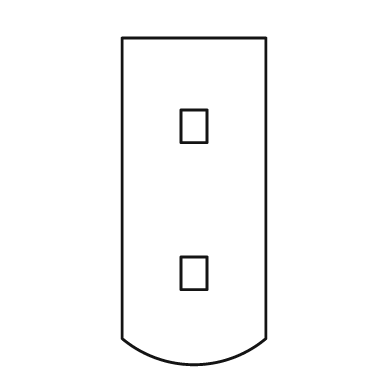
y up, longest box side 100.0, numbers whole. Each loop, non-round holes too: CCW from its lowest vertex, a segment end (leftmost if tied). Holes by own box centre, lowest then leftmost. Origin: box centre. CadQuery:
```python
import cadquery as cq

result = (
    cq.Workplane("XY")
    .moveTo(-22.0, -42.0)
    .threePointArc((0.0, -50.0), (22.0, -42.0))
    .lineTo(22.0, 50.0)
    .lineTo(-22.0, 50.0)
    .close()
    .moveTo(-4.0, -27.0)
    .lineTo(4.0, -27.0)
    .lineTo(4.0, -17.0)
    .lineTo(-4.0, -17.0)
    .close()
    .moveTo(-4.0, 18.0)
    .lineTo(4.0, 18.0)
    .lineTo(4.0, 28.0)
    .lineTo(-4.0, 28.0)
    .close()
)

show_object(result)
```